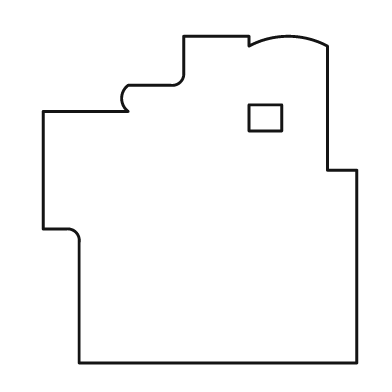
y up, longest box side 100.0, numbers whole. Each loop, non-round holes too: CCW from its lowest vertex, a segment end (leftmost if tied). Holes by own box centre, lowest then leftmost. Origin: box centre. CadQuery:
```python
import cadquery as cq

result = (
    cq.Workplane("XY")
    .moveTo(-37.0, -50.0)
    .lineTo(48.0, -50.0)
    .lineTo(48.0, 9.0)
    .lineTo(39.0, 9.0)
    .lineTo(39.0, 47.0)
    .threePointArc((27.0, 50.0), (15.0, 47.0))
    .lineTo(15.0, 50.0)
    .lineTo(-5.0, 50.0)
    .lineTo(-5.0, 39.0)
    .threePointArc((-6.0, 36.0), (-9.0, 35.0))
    .lineTo(-22.0, 35.0)
    .threePointArc((-24.0, 31.0), (-22.0, 27.0))
    .lineTo(-48.0, 27.0)
    .lineTo(-48.0, -9.0)
    .lineTo(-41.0, -9.0)
    .threePointArc((-38.0, -10.0), (-37.0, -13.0))
    .close()
    .moveTo(15.0, 21.0)
    .lineTo(25.0, 21.0)
    .lineTo(25.0, 29.0)
    .lineTo(15.0, 29.0)
    .close()
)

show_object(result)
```